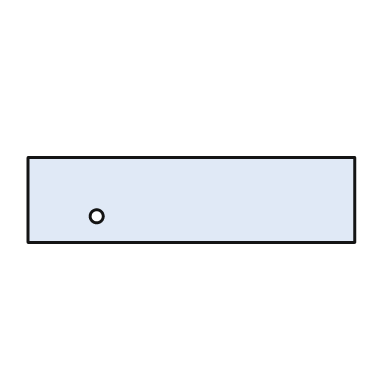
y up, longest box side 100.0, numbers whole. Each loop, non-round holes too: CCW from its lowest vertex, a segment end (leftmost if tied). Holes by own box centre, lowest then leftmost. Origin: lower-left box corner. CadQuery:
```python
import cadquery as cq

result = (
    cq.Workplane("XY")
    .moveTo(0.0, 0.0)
    .lineTo(100.0, 0.0)
    .lineTo(100.0, 26.0)
    .lineTo(0.0, 26.0)
    .close()
    .moveTo(21.0, 8.0)
    .circle(2.0)
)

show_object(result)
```